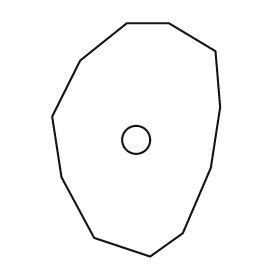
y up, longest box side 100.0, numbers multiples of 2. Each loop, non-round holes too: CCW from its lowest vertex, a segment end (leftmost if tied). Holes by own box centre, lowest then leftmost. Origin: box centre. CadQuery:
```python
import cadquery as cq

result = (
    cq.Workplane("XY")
    .moveTo(6.0, -50.0)
    .lineTo(20.0, -40.0)
    .lineTo(32.0, -12.0)
    .lineTo(36.0, 14.0)
    .lineTo(34.0, 38.0)
    .lineTo(14.0, 50.0)
    .lineTo(-4.0, 50.0)
    .lineTo(-24.0, 34.0)
    .lineTo(-36.0, 10.0)
    .lineTo(-32.0, -16.0)
    .lineTo(-18.0, -42.0)
    .close()
    .moveTo(0.0, 0.0)
    .circle(6.0)
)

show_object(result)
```